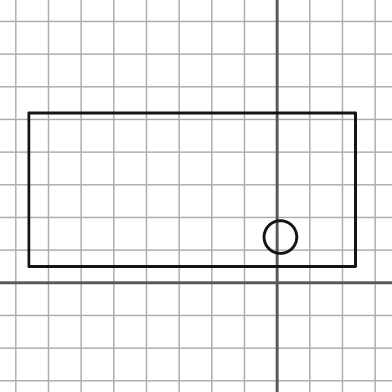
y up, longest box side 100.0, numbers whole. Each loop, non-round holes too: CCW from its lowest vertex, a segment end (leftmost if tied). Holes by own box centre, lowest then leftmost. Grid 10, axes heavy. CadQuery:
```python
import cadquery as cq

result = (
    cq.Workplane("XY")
    .moveTo(-76.0, 5.0)
    .lineTo(24.0, 5.0)
    .lineTo(24.0, 52.0)
    .lineTo(-76.0, 52.0)
    .close()
    .moveTo(1.0, 14.0)
    .circle(5.0)
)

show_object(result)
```